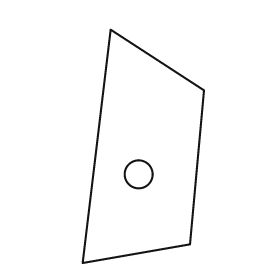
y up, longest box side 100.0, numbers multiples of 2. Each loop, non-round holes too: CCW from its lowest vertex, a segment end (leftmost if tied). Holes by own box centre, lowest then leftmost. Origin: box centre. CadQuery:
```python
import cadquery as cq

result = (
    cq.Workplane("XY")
    .moveTo(-26.0, -50.0)
    .lineTo(20.0, -42.0)
    .lineTo(26.0, 24.0)
    .lineTo(-14.0, 50.0)
    .close()
    .moveTo(-2.0, -12.0)
    .circle(6.0)
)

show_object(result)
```